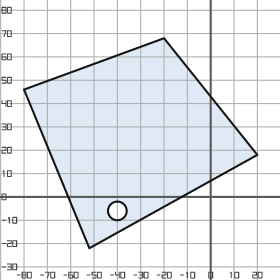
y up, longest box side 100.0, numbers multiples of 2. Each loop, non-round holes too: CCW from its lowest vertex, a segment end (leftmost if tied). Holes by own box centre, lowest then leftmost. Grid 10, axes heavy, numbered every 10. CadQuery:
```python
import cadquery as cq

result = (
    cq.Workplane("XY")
    .moveTo(-52.0, -22.0)
    .lineTo(20.0, 18.0)
    .lineTo(-20.0, 68.0)
    .lineTo(-80.0, 46.0)
    .close()
    .moveTo(-40.0, -6.0)
    .circle(4.0)
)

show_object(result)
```